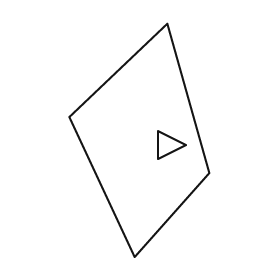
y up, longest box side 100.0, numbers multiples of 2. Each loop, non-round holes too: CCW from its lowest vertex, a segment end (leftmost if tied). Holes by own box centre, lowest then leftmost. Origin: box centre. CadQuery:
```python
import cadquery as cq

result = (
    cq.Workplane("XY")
    .moveTo(-2.0, -50.0)
    .lineTo(30.0, -14.0)
    .lineTo(12.0, 50.0)
    .lineTo(-30.0, 10.0)
    .close()
    .moveTo(8.0, -8.0)
    .lineTo(20.0, -2.0)
    .lineTo(8.0, 4.0)
    .close()
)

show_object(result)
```